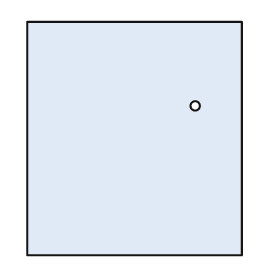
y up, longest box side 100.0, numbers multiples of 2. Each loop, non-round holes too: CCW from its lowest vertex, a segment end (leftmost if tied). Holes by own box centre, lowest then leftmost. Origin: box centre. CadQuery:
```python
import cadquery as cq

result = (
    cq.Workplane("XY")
    .moveTo(-46.0, -50.0)
    .lineTo(46.0, -50.0)
    .lineTo(46.0, 50.0)
    .lineTo(-46.0, 50.0)
    .close()
    .moveTo(26.0, 14.0)
    .circle(2.0)
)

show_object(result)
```